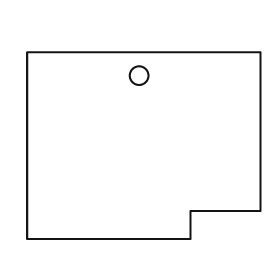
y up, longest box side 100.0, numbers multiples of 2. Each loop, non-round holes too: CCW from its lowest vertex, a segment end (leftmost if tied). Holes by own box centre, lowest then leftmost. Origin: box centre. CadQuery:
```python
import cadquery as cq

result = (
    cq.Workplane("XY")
    .moveTo(-50.0, -40.0)
    .lineTo(20.0, -40.0)
    .lineTo(20.0, -28.0)
    .lineTo(50.0, -28.0)
    .lineTo(50.0, 40.0)
    .lineTo(-50.0, 40.0)
    .close()
    .moveTo(-2.0, 30.0)
    .circle(4.0)
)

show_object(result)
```